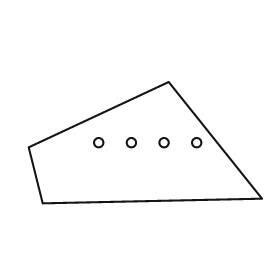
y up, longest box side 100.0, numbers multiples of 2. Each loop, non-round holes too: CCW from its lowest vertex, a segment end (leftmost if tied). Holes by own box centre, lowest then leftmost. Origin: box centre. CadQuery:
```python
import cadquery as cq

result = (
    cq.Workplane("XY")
    .moveTo(-44.0, -26.0)
    .lineTo(50.0, -24.0)
    .lineTo(10.0, 26.0)
    .lineTo(-50.0, -2.0)
    .close()
    .moveTo(-20.0, 0.0)
    .circle(2.0)
    .moveTo(-6.0, 0.0)
    .circle(2.0)
    .moveTo(8.0, 0.0)
    .circle(2.0)
    .moveTo(22.0, 0.0)
    .circle(2.0)
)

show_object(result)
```